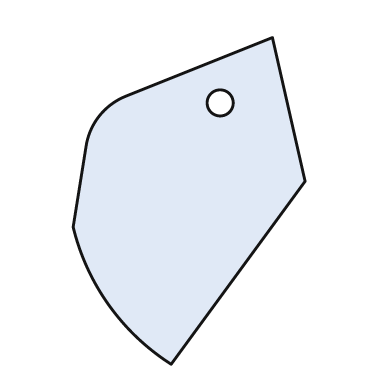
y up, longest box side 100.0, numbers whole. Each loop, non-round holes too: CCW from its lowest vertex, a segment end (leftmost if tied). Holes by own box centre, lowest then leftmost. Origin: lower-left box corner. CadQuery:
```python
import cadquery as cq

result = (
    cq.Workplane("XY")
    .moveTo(30.0, 0.0)
    .lineTo(71.0, 56.0)
    .lineTo(61.0, 100.0)
    .lineTo(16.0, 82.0)
    .threePointArc((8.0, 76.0), (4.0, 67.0))
    .lineTo(0.0, 42.0)
    .threePointArc((11.0, 18.0), (30.0, 0.0))
    .close()
    .moveTo(45.0, 80.0)
    .circle(4.0)
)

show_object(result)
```